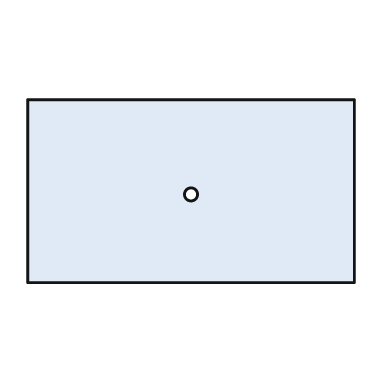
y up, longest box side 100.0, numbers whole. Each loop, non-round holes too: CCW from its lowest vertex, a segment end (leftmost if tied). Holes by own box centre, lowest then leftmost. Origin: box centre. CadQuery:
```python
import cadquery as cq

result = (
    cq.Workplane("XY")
    .moveTo(-50.0, -28.0)
    .lineTo(50.0, -28.0)
    .lineTo(50.0, 28.0)
    .lineTo(-50.0, 28.0)
    .close()
    .moveTo(0.0, -1.0)
    .circle(2.0)
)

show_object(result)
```